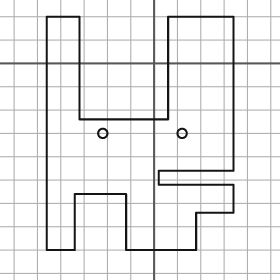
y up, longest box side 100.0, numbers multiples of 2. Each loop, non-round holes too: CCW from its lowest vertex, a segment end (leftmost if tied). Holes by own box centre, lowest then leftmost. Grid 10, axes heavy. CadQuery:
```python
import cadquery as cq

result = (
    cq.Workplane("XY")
    .moveTo(-46.0, -80.0)
    .lineTo(-34.0, -80.0)
    .lineTo(-34.0, -56.0)
    .lineTo(-12.0, -56.0)
    .lineTo(-12.0, -80.0)
    .lineTo(18.0, -80.0)
    .lineTo(18.0, -64.0)
    .lineTo(34.0, -64.0)
    .lineTo(34.0, -52.0)
    .lineTo(2.0, -52.0)
    .lineTo(2.0, -46.0)
    .lineTo(34.0, -46.0)
    .lineTo(34.0, 20.0)
    .lineTo(6.0, 20.0)
    .lineTo(6.0, -24.0)
    .lineTo(-32.0, -24.0)
    .lineTo(-32.0, 20.0)
    .lineTo(-46.0, 20.0)
    .close()
    .moveTo(-22.0, -30.0)
    .circle(2.0)
    .moveTo(12.0, -30.0)
    .circle(2.0)
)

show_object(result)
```